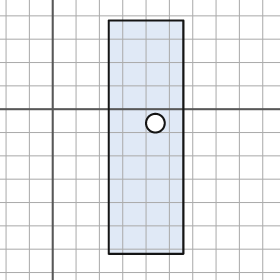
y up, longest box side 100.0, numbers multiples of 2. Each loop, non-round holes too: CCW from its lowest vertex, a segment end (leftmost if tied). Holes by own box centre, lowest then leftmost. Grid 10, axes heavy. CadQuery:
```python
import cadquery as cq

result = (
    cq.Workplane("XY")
    .moveTo(24.0, -62.0)
    .lineTo(56.0, -62.0)
    .lineTo(56.0, 38.0)
    .lineTo(24.0, 38.0)
    .close()
    .moveTo(44.0, -6.0)
    .circle(4.0)
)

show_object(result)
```